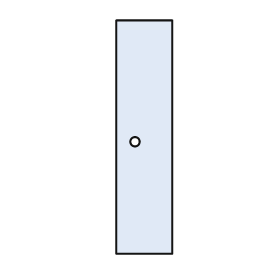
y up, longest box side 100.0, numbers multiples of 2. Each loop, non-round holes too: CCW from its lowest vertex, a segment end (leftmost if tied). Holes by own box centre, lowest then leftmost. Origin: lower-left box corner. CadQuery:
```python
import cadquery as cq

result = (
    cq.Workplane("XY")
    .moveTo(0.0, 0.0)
    .lineTo(24.0, 0.0)
    .lineTo(24.0, 100.0)
    .lineTo(0.0, 100.0)
    .close()
    .moveTo(8.0, 48.0)
    .circle(2.0)
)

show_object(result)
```